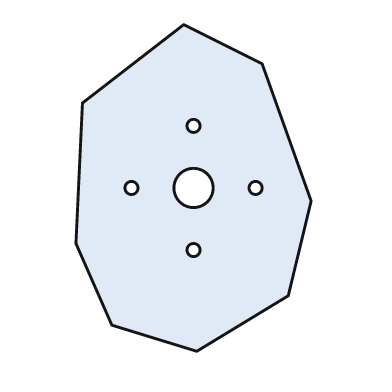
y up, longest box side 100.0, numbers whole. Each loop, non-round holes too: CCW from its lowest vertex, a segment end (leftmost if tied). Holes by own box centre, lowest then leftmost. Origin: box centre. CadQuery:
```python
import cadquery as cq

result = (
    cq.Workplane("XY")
    .moveTo(1.0, -50.0)
    .lineTo(29.0, -33.0)
    .lineTo(36.0, -4.0)
    .lineTo(21.0, 38.0)
    .lineTo(-3.0, 50.0)
    .lineTo(-34.0, 26.0)
    .lineTo(-36.0, -17.0)
    .lineTo(-25.0, -42.0)
    .close()
    .moveTo(0.0, -19.0)
    .circle(2.0)
    .moveTo(-19.0, 0.0)
    .circle(2.0)
    .moveTo(0.0, 0.0)
    .circle(6.0)
    .moveTo(19.0, 0.0)
    .circle(2.0)
    .moveTo(0.0, 19.0)
    .circle(2.0)
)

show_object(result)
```